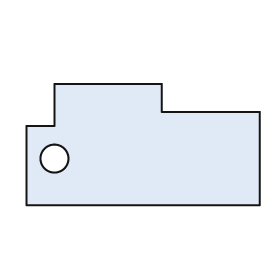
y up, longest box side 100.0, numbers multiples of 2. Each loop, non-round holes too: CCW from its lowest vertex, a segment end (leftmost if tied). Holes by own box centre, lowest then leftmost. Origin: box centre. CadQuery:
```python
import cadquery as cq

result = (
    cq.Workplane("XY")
    .moveTo(-50.0, -26.0)
    .lineTo(50.0, -26.0)
    .lineTo(50.0, 14.0)
    .lineTo(8.0, 14.0)
    .lineTo(8.0, 26.0)
    .lineTo(-38.0, 26.0)
    .lineTo(-38.0, 8.0)
    .lineTo(-50.0, 8.0)
    .close()
    .moveTo(-38.0, -6.0)
    .circle(6.0)
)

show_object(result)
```